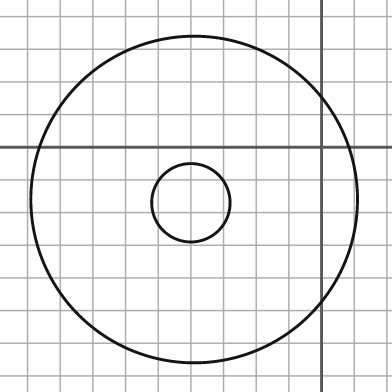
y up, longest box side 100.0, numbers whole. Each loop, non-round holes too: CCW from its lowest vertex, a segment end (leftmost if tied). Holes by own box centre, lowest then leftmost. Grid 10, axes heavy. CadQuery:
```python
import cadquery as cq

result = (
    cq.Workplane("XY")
    .moveTo(-39.0, -16.0)
    .circle(50.0)
    .moveTo(-40.0, -17.0)
    .circle(12.0)
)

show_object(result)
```